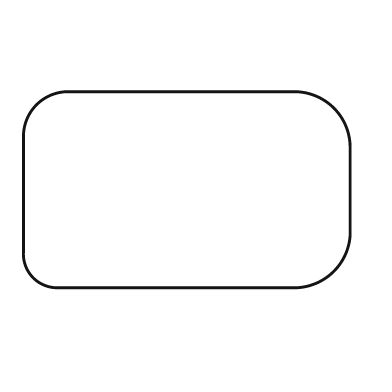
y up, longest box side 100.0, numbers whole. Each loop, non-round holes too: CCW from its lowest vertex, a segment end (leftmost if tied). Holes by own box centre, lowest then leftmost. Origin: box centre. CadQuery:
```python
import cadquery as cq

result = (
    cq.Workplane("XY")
    .moveTo(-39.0, -30.0)
    .lineTo(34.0, -30.0)
    .threePointArc((45.0, -25.0), (50.0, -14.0))
    .lineTo(50.0, 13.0)
    .threePointArc((45.0, 25.0), (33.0, 30.0))
    .lineTo(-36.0, 30.0)
    .threePointArc((-46.0, 26.0), (-50.0, 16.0))
    .lineTo(-50.0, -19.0)
    .threePointArc((-47.0, -27.0), (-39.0, -30.0))
    .close()
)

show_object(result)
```